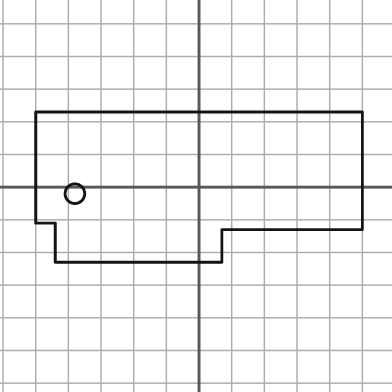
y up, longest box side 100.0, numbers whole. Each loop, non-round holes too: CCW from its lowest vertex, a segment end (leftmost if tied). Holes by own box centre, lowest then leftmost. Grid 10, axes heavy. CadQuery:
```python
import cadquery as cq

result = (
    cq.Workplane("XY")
    .moveTo(-44.0, -23.0)
    .lineTo(7.0, -23.0)
    .lineTo(7.0, -13.0)
    .lineTo(50.0, -13.0)
    .lineTo(50.0, 23.0)
    .lineTo(-50.0, 23.0)
    .lineTo(-50.0, -11.0)
    .lineTo(-44.0, -11.0)
    .close()
    .moveTo(-38.0, -2.0)
    .circle(3.0)
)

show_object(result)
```